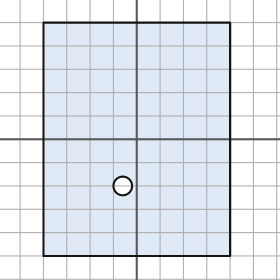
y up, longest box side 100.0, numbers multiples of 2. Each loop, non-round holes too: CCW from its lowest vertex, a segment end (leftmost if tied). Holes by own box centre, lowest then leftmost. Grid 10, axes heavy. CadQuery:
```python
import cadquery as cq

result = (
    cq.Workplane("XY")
    .moveTo(-40.0, -50.0)
    .lineTo(40.0, -50.0)
    .lineTo(40.0, 50.0)
    .lineTo(-40.0, 50.0)
    .close()
    .moveTo(-6.0, -20.0)
    .circle(4.0)
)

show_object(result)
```